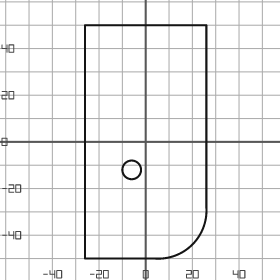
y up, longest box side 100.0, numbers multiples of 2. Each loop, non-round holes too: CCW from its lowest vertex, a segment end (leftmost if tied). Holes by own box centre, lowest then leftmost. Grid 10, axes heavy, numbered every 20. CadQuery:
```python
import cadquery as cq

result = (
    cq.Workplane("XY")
    .moveTo(-26.0, -50.0)
    .lineTo(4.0, -50.0)
    .threePointArc((20.0, -44.0), (26.0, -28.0))
    .lineTo(26.0, 50.0)
    .lineTo(-26.0, 50.0)
    .close()
    .moveTo(-6.0, -12.0)
    .circle(4.0)
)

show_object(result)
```